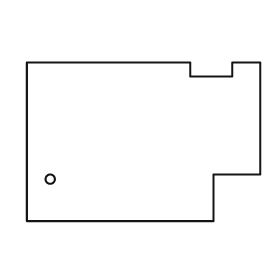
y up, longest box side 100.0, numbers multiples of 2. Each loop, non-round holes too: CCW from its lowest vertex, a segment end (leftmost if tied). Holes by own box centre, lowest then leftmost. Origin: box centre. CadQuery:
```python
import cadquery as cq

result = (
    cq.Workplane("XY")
    .moveTo(-50.0, -34.0)
    .lineTo(30.0, -34.0)
    .lineTo(30.0, -14.0)
    .lineTo(50.0, -14.0)
    .lineTo(50.0, 34.0)
    .lineTo(38.0, 34.0)
    .lineTo(38.0, 28.0)
    .lineTo(20.0, 28.0)
    .lineTo(20.0, 34.0)
    .lineTo(-50.0, 34.0)
    .close()
    .moveTo(-40.0, -16.0)
    .circle(2.0)
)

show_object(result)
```